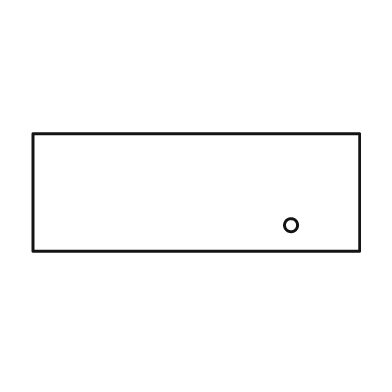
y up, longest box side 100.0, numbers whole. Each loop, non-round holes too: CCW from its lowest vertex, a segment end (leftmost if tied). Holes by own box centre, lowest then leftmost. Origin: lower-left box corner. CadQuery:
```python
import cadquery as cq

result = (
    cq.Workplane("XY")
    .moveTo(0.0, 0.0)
    .lineTo(100.0, 0.0)
    .lineTo(100.0, 36.0)
    .lineTo(0.0, 36.0)
    .close()
    .moveTo(79.0, 8.0)
    .circle(2.0)
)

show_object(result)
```